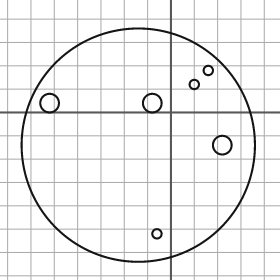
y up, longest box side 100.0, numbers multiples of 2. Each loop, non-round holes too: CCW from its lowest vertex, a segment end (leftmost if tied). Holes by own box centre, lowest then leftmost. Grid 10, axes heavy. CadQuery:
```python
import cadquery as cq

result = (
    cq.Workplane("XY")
    .moveTo(-14.0, -14.0)
    .circle(50.0)
    .moveTo(-6.0, -52.0)
    .circle(2.0)
    .moveTo(22.0, -14.0)
    .circle(4.0)
    .moveTo(-52.0, 4.0)
    .circle(4.0)
    .moveTo(-8.0, 4.0)
    .circle(4.0)
    .moveTo(10.0, 12.0)
    .circle(2.0)
    .moveTo(16.0, 18.0)
    .circle(2.0)
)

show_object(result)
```